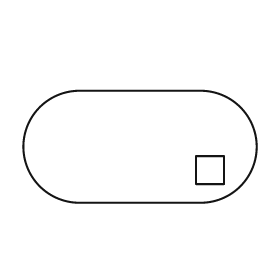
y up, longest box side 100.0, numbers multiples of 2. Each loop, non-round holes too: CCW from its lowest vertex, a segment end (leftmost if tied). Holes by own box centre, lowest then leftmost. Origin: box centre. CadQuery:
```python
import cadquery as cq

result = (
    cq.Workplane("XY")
    .moveTo(-26.0, -24.0)
    .lineTo(26.0, -24.0)
    .threePointArc((50.0, 0.0), (26.0, 24.0))
    .lineTo(-26.0, 24.0)
    .threePointArc((-50.0, 0.0), (-26.0, -24.0))
    .close()
    .moveTo(24.0, -16.0)
    .lineTo(36.0, -16.0)
    .lineTo(36.0, -4.0)
    .lineTo(24.0, -4.0)
    .close()
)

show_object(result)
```